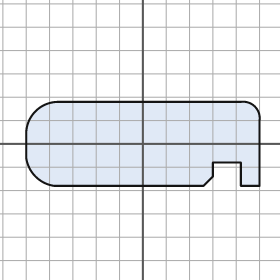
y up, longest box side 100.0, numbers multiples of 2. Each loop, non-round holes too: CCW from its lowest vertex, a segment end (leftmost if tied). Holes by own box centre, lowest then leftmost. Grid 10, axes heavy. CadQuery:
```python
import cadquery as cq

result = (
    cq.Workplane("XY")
    .moveTo(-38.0, -18.0)
    .lineTo(26.0, -18.0)
    .lineTo(30.0, -14.0)
    .lineTo(30.0, -8.0)
    .lineTo(42.0, -8.0)
    .lineTo(42.0, -18.0)
    .lineTo(50.0, -18.0)
    .lineTo(50.0, 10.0)
    .threePointArc((48.0, 16.0), (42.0, 18.0))
    .lineTo(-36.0, 18.0)
    .threePointArc((-46.0, 14.0), (-50.0, 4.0))
    .lineTo(-50.0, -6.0)
    .threePointArc((-46.0, -14.0), (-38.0, -18.0))
    .close()
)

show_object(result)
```